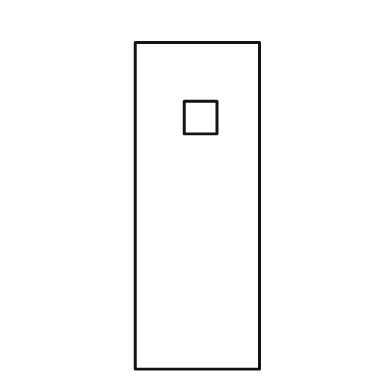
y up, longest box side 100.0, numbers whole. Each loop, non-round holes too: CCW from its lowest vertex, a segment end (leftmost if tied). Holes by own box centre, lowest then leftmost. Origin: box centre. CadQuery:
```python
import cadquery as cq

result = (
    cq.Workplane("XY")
    .moveTo(-19.0, -50.0)
    .lineTo(19.0, -50.0)
    .lineTo(19.0, 50.0)
    .lineTo(-19.0, 50.0)
    .close()
    .moveTo(-4.0, 22.0)
    .lineTo(6.0, 22.0)
    .lineTo(6.0, 32.0)
    .lineTo(-4.0, 32.0)
    .close()
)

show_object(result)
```